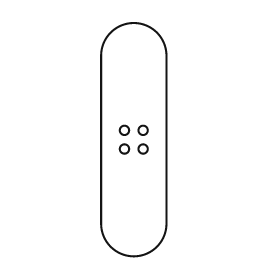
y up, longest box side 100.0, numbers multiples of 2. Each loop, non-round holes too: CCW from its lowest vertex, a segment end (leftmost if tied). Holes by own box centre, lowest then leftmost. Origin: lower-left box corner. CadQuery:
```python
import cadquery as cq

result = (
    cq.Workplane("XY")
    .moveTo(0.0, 14.0)
    .threePointArc((14.0, 0.0), (28.0, 14.0))
    .lineTo(28.0, 86.0)
    .threePointArc((14.0, 100.0), (0.0, 86.0))
    .close()
    .moveTo(10.0, 46.0)
    .circle(2.0)
    .moveTo(18.0, 46.0)
    .circle(2.0)
    .moveTo(10.0, 54.0)
    .circle(2.0)
    .moveTo(18.0, 54.0)
    .circle(2.0)
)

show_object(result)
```